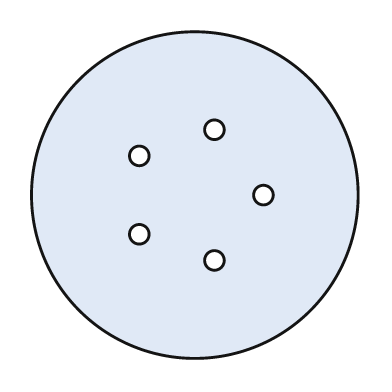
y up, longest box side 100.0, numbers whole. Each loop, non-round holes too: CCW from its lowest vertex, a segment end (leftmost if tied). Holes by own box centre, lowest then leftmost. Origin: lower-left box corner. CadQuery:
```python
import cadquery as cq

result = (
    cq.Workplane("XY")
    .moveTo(50.0, 50.0)
    .circle(50.0)
    .moveTo(56.0, 30.0)
    .circle(3.0)
    .moveTo(33.0, 38.0)
    .circle(3.0)
    .moveTo(71.0, 50.0)
    .circle(3.0)
    .moveTo(33.0, 62.0)
    .circle(3.0)
    .moveTo(56.0, 70.0)
    .circle(3.0)
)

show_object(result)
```